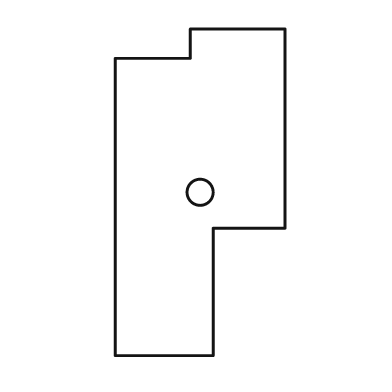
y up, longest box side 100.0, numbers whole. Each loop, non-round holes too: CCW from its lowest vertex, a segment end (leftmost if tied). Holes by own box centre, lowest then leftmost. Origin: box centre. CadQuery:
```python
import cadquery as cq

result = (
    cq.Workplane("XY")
    .moveTo(-26.0, -50.0)
    .lineTo(4.0, -50.0)
    .lineTo(4.0, -11.0)
    .lineTo(26.0, -11.0)
    .lineTo(26.0, 50.0)
    .lineTo(-3.0, 50.0)
    .lineTo(-3.0, 41.0)
    .lineTo(-26.0, 41.0)
    .close()
    .moveTo(0.0, 0.0)
    .circle(4.0)
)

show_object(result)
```